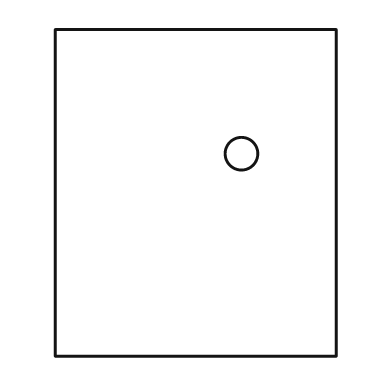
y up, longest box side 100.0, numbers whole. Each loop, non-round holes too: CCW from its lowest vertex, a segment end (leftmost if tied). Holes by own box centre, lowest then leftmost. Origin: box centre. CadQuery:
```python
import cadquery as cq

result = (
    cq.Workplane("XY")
    .moveTo(-43.0, -50.0)
    .lineTo(43.0, -50.0)
    .lineTo(43.0, 50.0)
    .lineTo(-43.0, 50.0)
    .close()
    .moveTo(14.0, 12.0)
    .circle(5.0)
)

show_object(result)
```